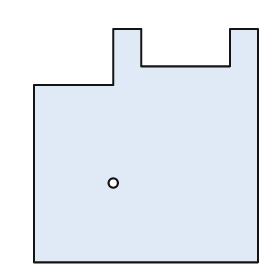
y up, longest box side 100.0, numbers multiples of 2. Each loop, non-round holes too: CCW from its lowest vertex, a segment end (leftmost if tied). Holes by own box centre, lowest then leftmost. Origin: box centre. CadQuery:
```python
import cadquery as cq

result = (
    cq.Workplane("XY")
    .moveTo(-48.0, -50.0)
    .lineTo(48.0, -50.0)
    .lineTo(48.0, 50.0)
    .lineTo(36.0, 50.0)
    .lineTo(36.0, 34.0)
    .lineTo(-2.0, 34.0)
    .lineTo(-2.0, 50.0)
    .lineTo(-14.0, 50.0)
    .lineTo(-14.0, 26.0)
    .lineTo(-48.0, 26.0)
    .close()
    .moveTo(-14.0, -16.0)
    .circle(2.0)
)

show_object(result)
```